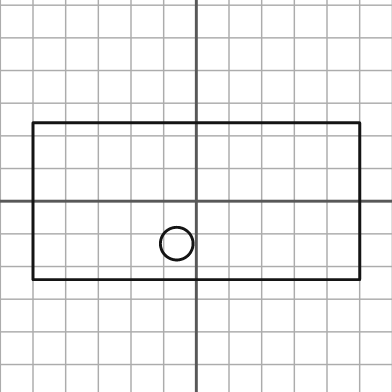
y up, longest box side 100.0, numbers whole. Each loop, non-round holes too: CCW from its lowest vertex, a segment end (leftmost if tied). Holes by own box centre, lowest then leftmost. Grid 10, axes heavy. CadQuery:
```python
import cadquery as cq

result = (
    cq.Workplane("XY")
    .moveTo(-50.0, -24.0)
    .lineTo(50.0, -24.0)
    .lineTo(50.0, 24.0)
    .lineTo(-50.0, 24.0)
    .close()
    .moveTo(-6.0, -13.0)
    .circle(5.0)
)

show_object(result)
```